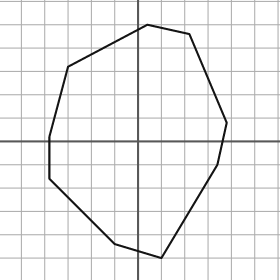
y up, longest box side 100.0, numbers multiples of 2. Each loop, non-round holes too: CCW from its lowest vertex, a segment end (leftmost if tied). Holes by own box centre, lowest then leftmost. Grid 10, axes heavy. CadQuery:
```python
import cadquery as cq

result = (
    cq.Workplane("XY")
    .moveTo(10.0, -50.0)
    .lineTo(34.0, -10.0)
    .lineTo(38.0, 8.0)
    .lineTo(22.0, 46.0)
    .lineTo(4.0, 50.0)
    .lineTo(-30.0, 32.0)
    .lineTo(-38.0, 2.0)
    .lineTo(-38.0, -16.0)
    .lineTo(-10.0, -44.0)
    .close()
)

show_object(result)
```